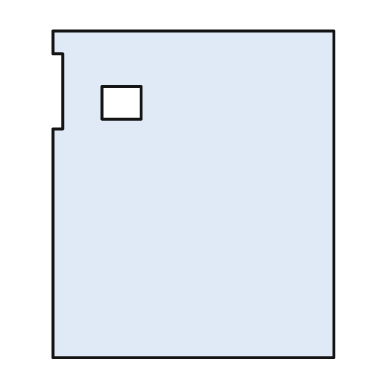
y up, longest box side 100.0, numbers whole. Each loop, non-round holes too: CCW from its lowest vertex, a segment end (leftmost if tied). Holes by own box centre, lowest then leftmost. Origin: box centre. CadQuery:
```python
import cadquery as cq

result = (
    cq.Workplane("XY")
    .moveTo(-43.0, -50.0)
    .lineTo(43.0, -50.0)
    .lineTo(43.0, 50.0)
    .lineTo(-43.0, 50.0)
    .lineTo(-43.0, 43.0)
    .lineTo(-40.0, 43.0)
    .lineTo(-40.0, 20.0)
    .lineTo(-43.0, 20.0)
    .close()
    .moveTo(-28.0, 23.0)
    .lineTo(-16.0, 23.0)
    .lineTo(-16.0, 33.0)
    .lineTo(-28.0, 33.0)
    .close()
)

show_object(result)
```